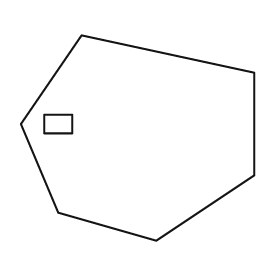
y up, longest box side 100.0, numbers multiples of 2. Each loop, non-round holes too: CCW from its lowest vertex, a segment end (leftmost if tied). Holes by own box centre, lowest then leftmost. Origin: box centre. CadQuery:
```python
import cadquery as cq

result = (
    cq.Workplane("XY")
    .moveTo(8.0, -44.0)
    .lineTo(50.0, -16.0)
    .lineTo(50.0, 28.0)
    .lineTo(-24.0, 44.0)
    .lineTo(-50.0, 6.0)
    .lineTo(-34.0, -32.0)
    .close()
    .moveTo(-40.0, 2.0)
    .lineTo(-28.0, 2.0)
    .lineTo(-28.0, 10.0)
    .lineTo(-40.0, 10.0)
    .close()
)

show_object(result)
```